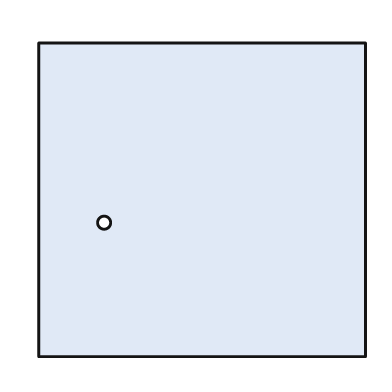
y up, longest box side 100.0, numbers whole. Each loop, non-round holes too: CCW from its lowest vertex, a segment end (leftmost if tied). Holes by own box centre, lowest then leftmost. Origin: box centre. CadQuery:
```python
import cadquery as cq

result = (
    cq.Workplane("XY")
    .moveTo(-50.0, -48.0)
    .lineTo(50.0, -48.0)
    .lineTo(50.0, 48.0)
    .lineTo(-50.0, 48.0)
    .close()
    .moveTo(-30.0, -7.0)
    .circle(2.0)
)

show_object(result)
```